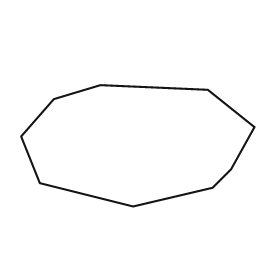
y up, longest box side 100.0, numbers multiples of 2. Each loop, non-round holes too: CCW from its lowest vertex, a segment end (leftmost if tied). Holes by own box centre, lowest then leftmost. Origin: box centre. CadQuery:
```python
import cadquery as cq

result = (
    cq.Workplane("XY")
    .moveTo(-2.0, -26.0)
    .lineTo(32.0, -18.0)
    .lineTo(40.0, -10.0)
    .lineTo(50.0, 8.0)
    .lineTo(30.0, 24.0)
    .lineTo(-16.0, 26.0)
    .lineTo(-36.0, 20.0)
    .lineTo(-50.0, 4.0)
    .lineTo(-42.0, -16.0)
    .close()
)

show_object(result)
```